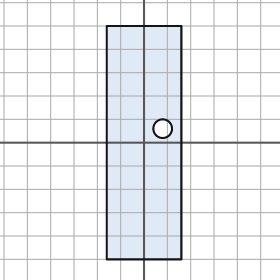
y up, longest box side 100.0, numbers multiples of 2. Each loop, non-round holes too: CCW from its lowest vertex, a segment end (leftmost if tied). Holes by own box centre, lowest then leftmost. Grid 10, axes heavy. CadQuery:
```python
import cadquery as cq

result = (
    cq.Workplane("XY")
    .moveTo(-16.0, -50.0)
    .lineTo(16.0, -50.0)
    .lineTo(16.0, 50.0)
    .lineTo(-16.0, 50.0)
    .close()
    .moveTo(8.0, 6.0)
    .circle(4.0)
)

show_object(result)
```